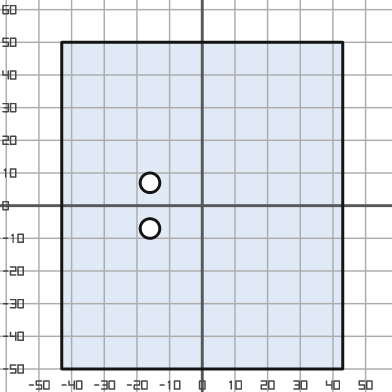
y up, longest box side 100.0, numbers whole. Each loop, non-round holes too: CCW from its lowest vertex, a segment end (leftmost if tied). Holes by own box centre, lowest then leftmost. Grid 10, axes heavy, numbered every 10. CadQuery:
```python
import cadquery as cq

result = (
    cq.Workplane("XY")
    .moveTo(-43.0, -50.0)
    .lineTo(43.0, -50.0)
    .lineTo(43.0, 50.0)
    .lineTo(-43.0, 50.0)
    .close()
    .moveTo(-16.0, -7.0)
    .circle(3.0)
    .moveTo(-16.0, 7.0)
    .circle(3.0)
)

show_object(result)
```